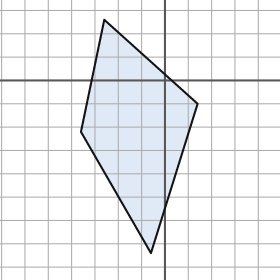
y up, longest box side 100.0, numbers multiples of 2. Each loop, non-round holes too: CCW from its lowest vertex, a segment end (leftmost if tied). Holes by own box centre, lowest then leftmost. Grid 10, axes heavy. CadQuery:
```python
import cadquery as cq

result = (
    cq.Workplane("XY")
    .moveTo(-6.0, -74.0)
    .lineTo(14.0, -10.0)
    .lineTo(-26.0, 26.0)
    .lineTo(-36.0, -22.0)
    .close()
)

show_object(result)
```